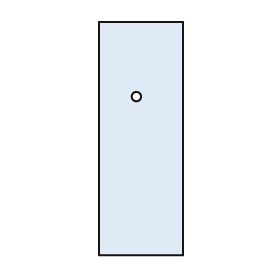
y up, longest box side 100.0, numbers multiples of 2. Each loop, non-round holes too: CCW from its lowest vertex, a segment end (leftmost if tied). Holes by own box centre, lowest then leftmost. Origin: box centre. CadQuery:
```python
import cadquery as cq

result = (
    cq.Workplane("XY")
    .moveTo(-18.0, -50.0)
    .lineTo(18.0, -50.0)
    .lineTo(18.0, 50.0)
    .lineTo(-18.0, 50.0)
    .close()
    .moveTo(-2.0, 18.0)
    .circle(2.0)
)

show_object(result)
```